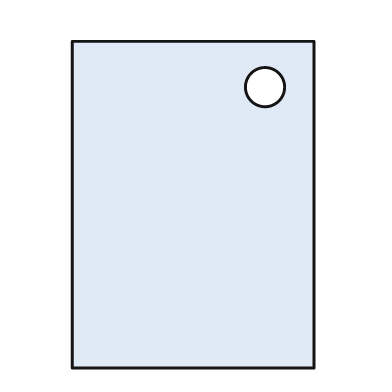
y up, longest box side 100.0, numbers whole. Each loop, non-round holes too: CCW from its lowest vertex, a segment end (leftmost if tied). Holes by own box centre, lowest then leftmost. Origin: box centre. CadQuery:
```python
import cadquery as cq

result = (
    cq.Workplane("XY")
    .moveTo(-37.0, -50.0)
    .lineTo(37.0, -50.0)
    .lineTo(37.0, 50.0)
    .lineTo(-37.0, 50.0)
    .close()
    .moveTo(22.0, 36.0)
    .circle(6.0)
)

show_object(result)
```